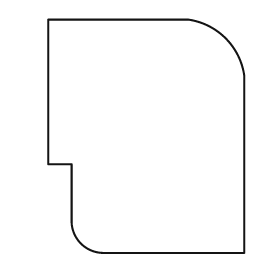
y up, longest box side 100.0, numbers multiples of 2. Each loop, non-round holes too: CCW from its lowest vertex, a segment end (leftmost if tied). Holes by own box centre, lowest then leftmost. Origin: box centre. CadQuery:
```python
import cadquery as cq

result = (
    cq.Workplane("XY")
    .moveTo(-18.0, -50.0)
    .lineTo(42.0, -50.0)
    .lineTo(42.0, 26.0)
    .threePointArc((34.0, 42.0), (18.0, 50.0))
    .lineTo(-42.0, 50.0)
    .lineTo(-42.0, -12.0)
    .lineTo(-32.0, -12.0)
    .lineTo(-32.0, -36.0)
    .threePointArc((-28.0, -46.0), (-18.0, -50.0))
    .close()
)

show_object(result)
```